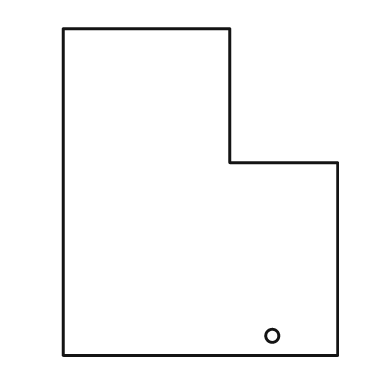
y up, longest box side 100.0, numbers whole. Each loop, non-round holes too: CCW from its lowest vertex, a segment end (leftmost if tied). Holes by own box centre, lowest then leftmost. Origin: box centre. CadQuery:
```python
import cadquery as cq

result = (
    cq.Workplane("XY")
    .moveTo(-42.0, -50.0)
    .lineTo(42.0, -50.0)
    .lineTo(42.0, 9.0)
    .lineTo(9.0, 9.0)
    .lineTo(9.0, 50.0)
    .lineTo(-42.0, 50.0)
    .close()
    .moveTo(22.0, -44.0)
    .circle(2.0)
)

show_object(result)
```